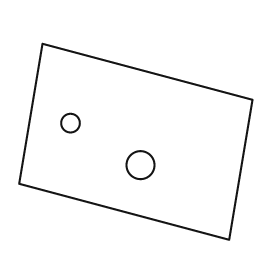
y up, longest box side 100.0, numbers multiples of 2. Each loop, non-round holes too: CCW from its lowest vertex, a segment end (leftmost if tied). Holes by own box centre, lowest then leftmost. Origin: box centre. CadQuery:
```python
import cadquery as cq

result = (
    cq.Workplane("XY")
    .moveTo(40.0, -42.0)
    .lineTo(50.0, 18.0)
    .lineTo(-40.0, 42.0)
    .lineTo(-50.0, -18.0)
    .close()
    .moveTo(2.0, -10.0)
    .circle(6.0)
    .moveTo(-28.0, 8.0)
    .circle(4.0)
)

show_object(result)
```